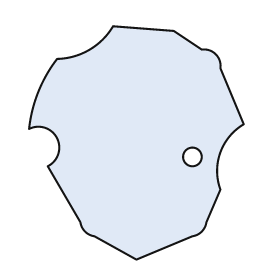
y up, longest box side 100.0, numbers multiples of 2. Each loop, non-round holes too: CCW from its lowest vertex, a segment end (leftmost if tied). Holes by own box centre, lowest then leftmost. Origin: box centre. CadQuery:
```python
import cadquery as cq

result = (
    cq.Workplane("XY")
    .moveTo(0.0, -50.0)
    .lineTo(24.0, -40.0)
    .threePointArc((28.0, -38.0), (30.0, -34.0))
    .lineTo(36.0, -20.0)
    .threePointArc((36.0, -4.0), (46.0, 8.0))
    .lineTo(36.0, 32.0)
    .threePointArc((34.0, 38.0), (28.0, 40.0))
    .lineTo(16.0, 48.0)
    .lineTo(-10.0, 50.0)
    .threePointArc((-20.0, 40.0), (-34.0, 36.0))
    .threePointArc((-42.0, 22.0), (-46.0, 6.0))
    .threePointArc((-34.0, 2.0), (-38.0, -10.0))
    .lineTo(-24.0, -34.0)
    .threePointArc((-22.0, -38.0), (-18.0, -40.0))
    .close()
    .moveTo(24.0, -6.0)
    .circle(4.0)
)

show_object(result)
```